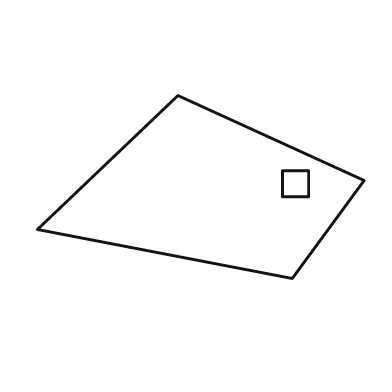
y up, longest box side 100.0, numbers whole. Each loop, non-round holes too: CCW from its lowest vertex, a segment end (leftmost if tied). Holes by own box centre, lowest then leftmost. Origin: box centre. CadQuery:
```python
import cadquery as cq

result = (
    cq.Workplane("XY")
    .moveTo(28.0, -28.0)
    .lineTo(50.0, 2.0)
    .lineTo(-7.0, 28.0)
    .lineTo(-50.0, -13.0)
    .close()
    .moveTo(25.0, -3.0)
    .lineTo(33.0, -3.0)
    .lineTo(33.0, 5.0)
    .lineTo(25.0, 5.0)
    .close()
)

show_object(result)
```